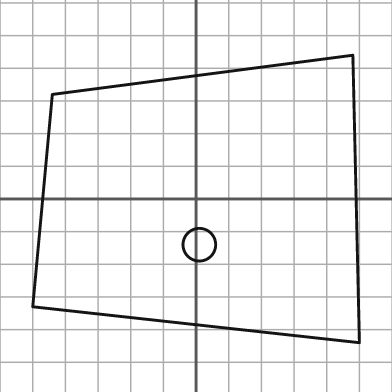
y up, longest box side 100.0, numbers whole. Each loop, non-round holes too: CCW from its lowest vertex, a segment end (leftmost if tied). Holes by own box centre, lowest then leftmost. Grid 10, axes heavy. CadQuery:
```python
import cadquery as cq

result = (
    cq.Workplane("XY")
    .moveTo(50.0, -44.0)
    .lineTo(48.0, 44.0)
    .lineTo(-44.0, 32.0)
    .lineTo(-50.0, -33.0)
    .close()
    .moveTo(1.0, -14.0)
    .circle(5.0)
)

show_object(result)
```